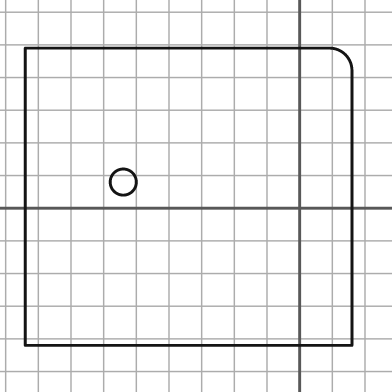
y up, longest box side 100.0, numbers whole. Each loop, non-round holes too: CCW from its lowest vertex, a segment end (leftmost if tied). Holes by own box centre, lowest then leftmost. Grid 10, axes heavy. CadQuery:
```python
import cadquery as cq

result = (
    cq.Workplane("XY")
    .moveTo(-84.0, -42.0)
    .lineTo(16.0, -42.0)
    .lineTo(16.0, 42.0)
    .threePointArc((14.0, 47.0), (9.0, 49.0))
    .lineTo(-84.0, 49.0)
    .close()
    .moveTo(-54.0, 8.0)
    .circle(4.0)
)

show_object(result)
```